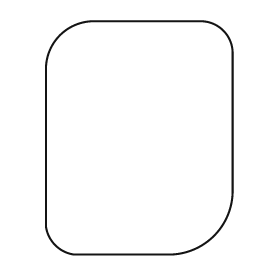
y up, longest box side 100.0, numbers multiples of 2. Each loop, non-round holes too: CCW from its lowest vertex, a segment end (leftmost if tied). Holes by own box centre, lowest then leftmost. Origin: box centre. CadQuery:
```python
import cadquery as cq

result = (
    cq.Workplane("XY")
    .moveTo(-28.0, -50.0)
    .lineTo(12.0, -50.0)
    .threePointArc((32.0, -42.0), (40.0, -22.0))
    .lineTo(40.0, 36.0)
    .threePointArc((36.0, 46.0), (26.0, 50.0))
    .lineTo(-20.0, 50.0)
    .threePointArc((-34.0, 44.0), (-40.0, 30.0))
    .lineTo(-40.0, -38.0)
    .threePointArc((-36.0, -46.0), (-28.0, -50.0))
    .close()
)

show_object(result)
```